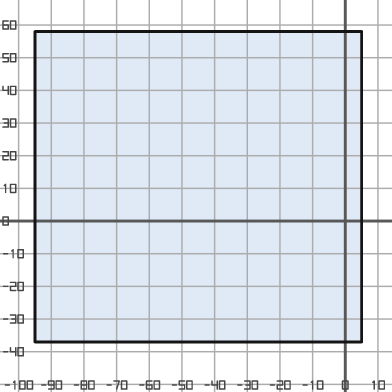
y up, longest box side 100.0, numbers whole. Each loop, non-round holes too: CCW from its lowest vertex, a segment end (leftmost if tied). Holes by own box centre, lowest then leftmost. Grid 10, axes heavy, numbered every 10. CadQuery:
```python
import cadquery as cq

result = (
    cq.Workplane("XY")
    .moveTo(-95.0, -37.0)
    .lineTo(5.0, -37.0)
    .lineTo(5.0, 58.0)
    .lineTo(-95.0, 58.0)
    .close()
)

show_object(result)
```